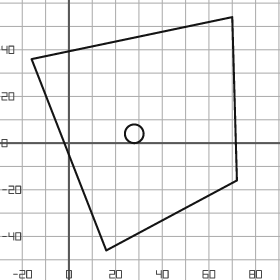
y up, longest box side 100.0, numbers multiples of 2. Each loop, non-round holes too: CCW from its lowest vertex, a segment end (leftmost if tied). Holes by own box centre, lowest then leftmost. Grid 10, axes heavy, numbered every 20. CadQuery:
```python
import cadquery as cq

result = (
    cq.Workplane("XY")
    .moveTo(16.0, -46.0)
    .lineTo(72.0, -16.0)
    .lineTo(70.0, 54.0)
    .lineTo(-16.0, 36.0)
    .close()
    .moveTo(28.0, 4.0)
    .circle(4.0)
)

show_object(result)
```